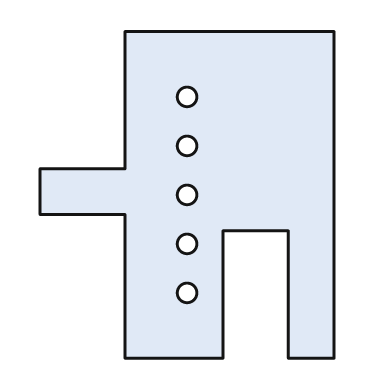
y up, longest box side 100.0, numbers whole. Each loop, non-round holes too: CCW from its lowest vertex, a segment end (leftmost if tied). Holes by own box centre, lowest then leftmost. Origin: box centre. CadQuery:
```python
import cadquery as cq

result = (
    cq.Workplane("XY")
    .moveTo(-19.0, -50.0)
    .lineTo(11.0, -50.0)
    .lineTo(11.0, -11.0)
    .lineTo(31.0, -11.0)
    .lineTo(31.0, -50.0)
    .lineTo(45.0, -50.0)
    .lineTo(45.0, 50.0)
    .lineTo(-19.0, 50.0)
    .lineTo(-19.0, 8.0)
    .lineTo(-45.0, 8.0)
    .lineTo(-45.0, -6.0)
    .lineTo(-19.0, -6.0)
    .close()
    .moveTo(0.0, -30.0)
    .circle(3.0)
    .moveTo(0.0, -15.0)
    .circle(3.0)
    .moveTo(0.0, 0.0)
    .circle(3.0)
    .moveTo(0.0, 15.0)
    .circle(3.0)
    .moveTo(0.0, 30.0)
    .circle(3.0)
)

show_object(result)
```